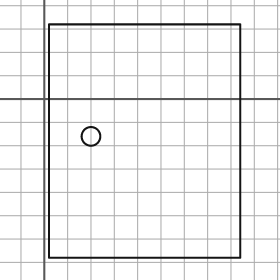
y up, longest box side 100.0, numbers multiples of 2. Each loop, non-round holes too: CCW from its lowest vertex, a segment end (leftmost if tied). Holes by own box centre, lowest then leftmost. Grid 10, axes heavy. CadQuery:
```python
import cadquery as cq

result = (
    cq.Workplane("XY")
    .moveTo(2.0, -68.0)
    .lineTo(84.0, -68.0)
    .lineTo(84.0, 32.0)
    .lineTo(2.0, 32.0)
    .close()
    .moveTo(20.0, -16.0)
    .circle(4.0)
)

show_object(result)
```